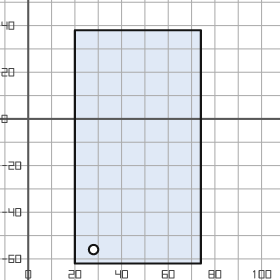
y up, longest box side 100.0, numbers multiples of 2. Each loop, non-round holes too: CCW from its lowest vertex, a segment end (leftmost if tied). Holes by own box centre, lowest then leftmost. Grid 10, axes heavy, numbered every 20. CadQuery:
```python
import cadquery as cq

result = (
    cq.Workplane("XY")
    .moveTo(20.0, -62.0)
    .lineTo(74.0, -62.0)
    .lineTo(74.0, 38.0)
    .lineTo(20.0, 38.0)
    .close()
    .moveTo(28.0, -56.0)
    .circle(2.0)
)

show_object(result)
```